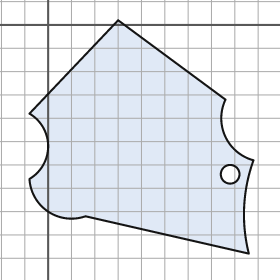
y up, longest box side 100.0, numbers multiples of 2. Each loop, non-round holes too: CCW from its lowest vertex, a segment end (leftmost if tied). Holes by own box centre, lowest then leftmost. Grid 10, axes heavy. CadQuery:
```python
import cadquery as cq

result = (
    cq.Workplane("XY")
    .moveTo(86.0, -98.0)
    .threePointArc((84.0, -78.0), (88.0, -58.0))
    .threePointArc((76.0, -48.0), (76.0, -32.0))
    .lineTo(30.0, 2.0)
    .lineTo(-8.0, -38.0)
    .threePointArc((0.0, -52.0), (-8.0, -66.0))
    .threePointArc((0.0, -80.0), (16.0, -82.0))
    .close()
    .moveTo(78.0, -64.0)
    .circle(4.0)
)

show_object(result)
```